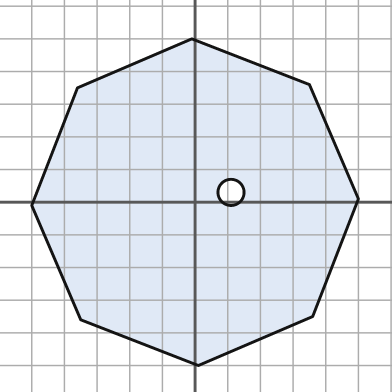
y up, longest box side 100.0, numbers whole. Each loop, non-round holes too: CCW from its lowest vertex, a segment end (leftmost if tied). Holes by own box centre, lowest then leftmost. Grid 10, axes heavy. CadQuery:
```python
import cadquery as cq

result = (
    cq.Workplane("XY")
    .moveTo(1.0, -50.0)
    .lineTo(36.0, -35.0)
    .lineTo(50.0, 1.0)
    .lineTo(35.0, 36.0)
    .lineTo(-1.0, 50.0)
    .lineTo(-36.0, 35.0)
    .lineTo(-50.0, -1.0)
    .lineTo(-35.0, -36.0)
    .close()
    .moveTo(11.0, 3.0)
    .circle(4.0)
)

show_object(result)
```